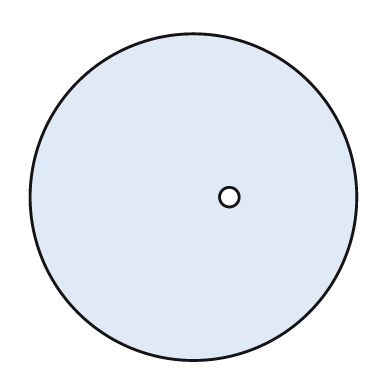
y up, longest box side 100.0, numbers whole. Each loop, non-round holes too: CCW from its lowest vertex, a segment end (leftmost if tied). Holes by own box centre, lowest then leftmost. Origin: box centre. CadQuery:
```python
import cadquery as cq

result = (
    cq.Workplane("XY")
    .moveTo(0.0, 0.0)
    .circle(50.0)
    .moveTo(11.0, 0.0)
    .circle(3.0)
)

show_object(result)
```